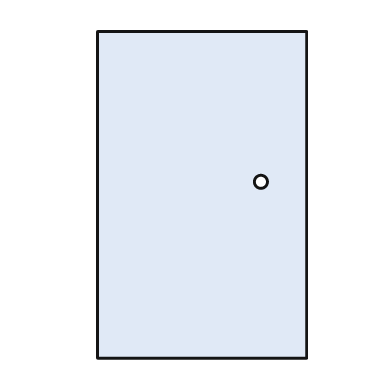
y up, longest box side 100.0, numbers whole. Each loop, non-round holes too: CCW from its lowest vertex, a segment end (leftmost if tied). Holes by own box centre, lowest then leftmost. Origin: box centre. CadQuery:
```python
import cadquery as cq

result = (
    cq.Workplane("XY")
    .moveTo(-32.0, -50.0)
    .lineTo(32.0, -50.0)
    .lineTo(32.0, 50.0)
    .lineTo(-32.0, 50.0)
    .close()
    .moveTo(18.0, 4.0)
    .circle(2.0)
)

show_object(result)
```